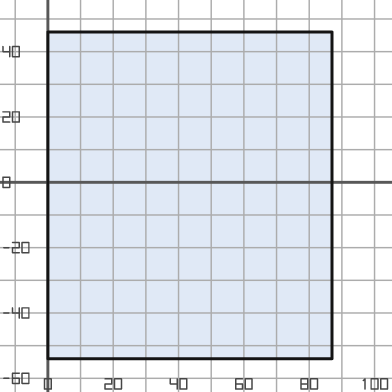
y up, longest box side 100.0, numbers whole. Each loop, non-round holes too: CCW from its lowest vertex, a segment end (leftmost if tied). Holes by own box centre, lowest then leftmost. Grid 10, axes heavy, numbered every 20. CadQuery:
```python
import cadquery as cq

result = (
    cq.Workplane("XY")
    .moveTo(0.0, -54.0)
    .lineTo(87.0, -54.0)
    .lineTo(87.0, 46.0)
    .lineTo(0.0, 46.0)
    .close()
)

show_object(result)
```